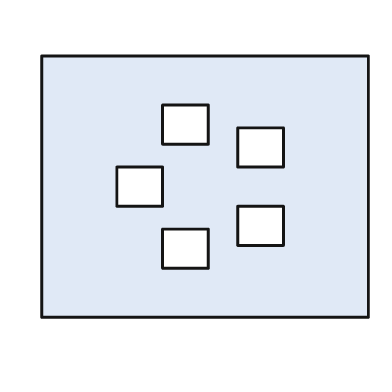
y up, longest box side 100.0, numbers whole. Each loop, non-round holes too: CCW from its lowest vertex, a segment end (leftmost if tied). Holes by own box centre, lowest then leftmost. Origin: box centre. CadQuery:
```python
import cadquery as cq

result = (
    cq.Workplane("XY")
    .moveTo(-50.0, -40.0)
    .lineTo(50.0, -40.0)
    .lineTo(50.0, 40.0)
    .lineTo(-50.0, 40.0)
    .close()
    .moveTo(-13.0, -25.0)
    .lineTo(1.0, -25.0)
    .lineTo(1.0, -13.0)
    .lineTo(-13.0, -13.0)
    .close()
    .moveTo(10.0, -18.0)
    .lineTo(24.0, -18.0)
    .lineTo(24.0, -6.0)
    .lineTo(10.0, -6.0)
    .close()
    .moveTo(-27.0, -6.0)
    .lineTo(-13.0, -6.0)
    .lineTo(-13.0, 6.0)
    .lineTo(-27.0, 6.0)
    .close()
    .moveTo(10.0, 6.0)
    .lineTo(24.0, 6.0)
    .lineTo(24.0, 18.0)
    .lineTo(10.0, 18.0)
    .close()
    .moveTo(-13.0, 13.0)
    .lineTo(1.0, 13.0)
    .lineTo(1.0, 25.0)
    .lineTo(-13.0, 25.0)
    .close()
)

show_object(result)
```